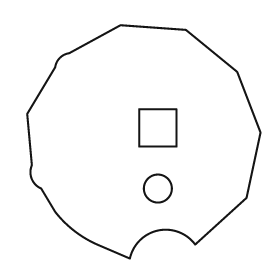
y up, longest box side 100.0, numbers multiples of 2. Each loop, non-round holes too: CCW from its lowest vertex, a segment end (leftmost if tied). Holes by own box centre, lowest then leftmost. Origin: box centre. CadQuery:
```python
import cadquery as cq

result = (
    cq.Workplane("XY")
    .moveTo(-6.0, -50.0)
    .threePointArc((6.0, -38.0), (22.0, -44.0))
    .lineTo(44.0, -24.0)
    .lineTo(50.0, 4.0)
    .lineTo(40.0, 30.0)
    .lineTo(18.0, 48.0)
    .lineTo(-10.0, 50.0)
    .lineTo(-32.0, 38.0)
    .threePointArc((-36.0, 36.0), (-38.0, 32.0))
    .lineTo(-50.0, 12.0)
    .lineTo(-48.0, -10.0)
    .threePointArc((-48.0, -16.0), (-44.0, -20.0))
    .lineTo(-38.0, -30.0)
    .threePointArc((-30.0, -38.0), (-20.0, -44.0))
    .close()
    .moveTo(6.0, -20.0)
    .circle(6.0)
    .moveTo(-2.0, -2.0)
    .lineTo(14.0, -2.0)
    .lineTo(14.0, 14.0)
    .lineTo(-2.0, 14.0)
    .close()
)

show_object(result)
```